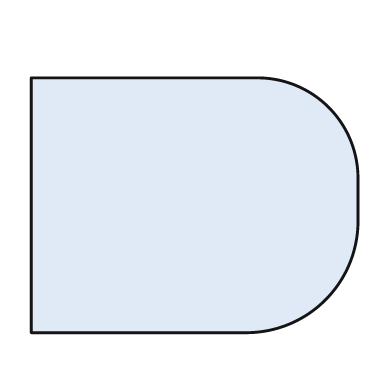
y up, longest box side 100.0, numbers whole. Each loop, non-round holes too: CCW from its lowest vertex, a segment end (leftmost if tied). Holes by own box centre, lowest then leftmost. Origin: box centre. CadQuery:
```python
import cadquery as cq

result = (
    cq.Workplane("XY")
    .moveTo(-50.0, -39.0)
    .lineTo(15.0, -39.0)
    .threePointArc((40.0, -29.0), (50.0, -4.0))
    .lineTo(50.0, 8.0)
    .threePointArc((41.0, 30.0), (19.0, 39.0))
    .lineTo(-50.0, 39.0)
    .close()
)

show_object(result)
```